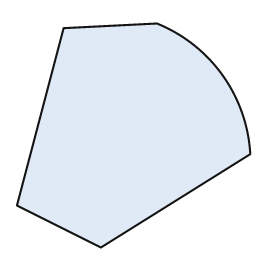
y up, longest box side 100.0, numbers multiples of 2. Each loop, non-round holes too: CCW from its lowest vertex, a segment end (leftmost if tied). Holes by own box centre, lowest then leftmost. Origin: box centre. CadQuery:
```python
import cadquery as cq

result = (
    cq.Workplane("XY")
    .moveTo(-14.0, -48.0)
    .lineTo(50.0, -8.0)
    .threePointArc((38.0, 26.0), (10.0, 48.0))
    .lineTo(-30.0, 46.0)
    .lineTo(-50.0, -30.0)
    .close()
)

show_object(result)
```